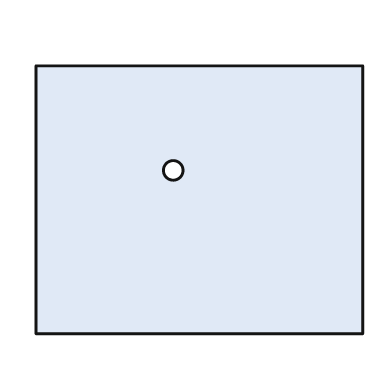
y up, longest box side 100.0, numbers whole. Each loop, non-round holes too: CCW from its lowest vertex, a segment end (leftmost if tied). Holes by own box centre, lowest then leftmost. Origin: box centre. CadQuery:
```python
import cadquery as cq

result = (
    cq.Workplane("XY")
    .moveTo(-50.0, -41.0)
    .lineTo(50.0, -41.0)
    .lineTo(50.0, 41.0)
    .lineTo(-50.0, 41.0)
    .close()
    .moveTo(-8.0, 9.0)
    .circle(3.0)
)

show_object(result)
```